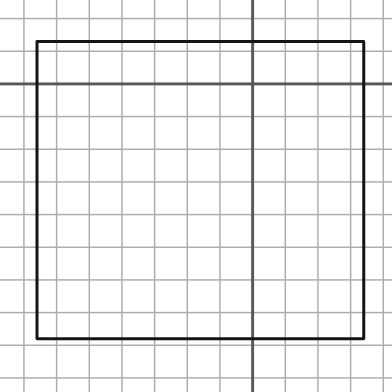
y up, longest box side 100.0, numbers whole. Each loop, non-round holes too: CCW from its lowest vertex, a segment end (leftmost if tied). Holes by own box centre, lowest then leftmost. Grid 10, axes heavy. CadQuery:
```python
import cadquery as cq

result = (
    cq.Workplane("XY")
    .moveTo(-66.0, -78.0)
    .lineTo(34.0, -78.0)
    .lineTo(34.0, 13.0)
    .lineTo(-66.0, 13.0)
    .close()
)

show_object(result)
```